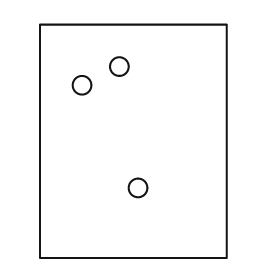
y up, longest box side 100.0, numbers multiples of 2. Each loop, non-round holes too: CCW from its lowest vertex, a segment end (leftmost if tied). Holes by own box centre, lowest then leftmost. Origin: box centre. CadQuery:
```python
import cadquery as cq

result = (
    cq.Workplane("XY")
    .moveTo(-40.0, -50.0)
    .lineTo(40.0, -50.0)
    .lineTo(40.0, 50.0)
    .lineTo(-40.0, 50.0)
    .close()
    .moveTo(2.0, -20.0)
    .circle(4.0)
    .moveTo(-22.0, 24.0)
    .circle(4.0)
    .moveTo(-6.0, 32.0)
    .circle(4.0)
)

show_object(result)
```